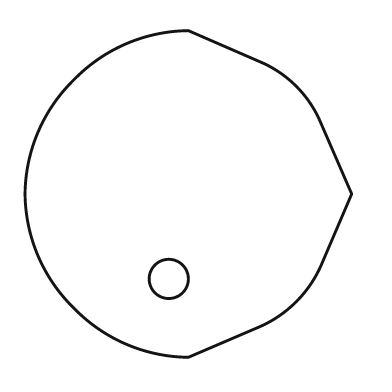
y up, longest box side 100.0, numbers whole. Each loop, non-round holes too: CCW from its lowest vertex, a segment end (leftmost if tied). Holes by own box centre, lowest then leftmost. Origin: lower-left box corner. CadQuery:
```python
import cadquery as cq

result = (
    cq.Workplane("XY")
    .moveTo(50.0, 0.0)
    .lineTo(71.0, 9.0)
    .threePointArc((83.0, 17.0), (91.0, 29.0))
    .lineTo(100.0, 50.0)
    .lineTo(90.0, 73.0)
    .threePointArc((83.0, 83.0), (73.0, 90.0))
    .lineTo(50.0, 100.0)
    .threePointArc((31.0, 96.0), (15.0, 85.0))
    .threePointArc((4.0, 69.0), (0.0, 50.0))
    .threePointArc((4.0, 31.0), (15.0, 15.0))
    .threePointArc((31.0, 4.0), (50.0, 0.0))
    .close()
    .moveTo(44.0, 24.0)
    .circle(6.0)
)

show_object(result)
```